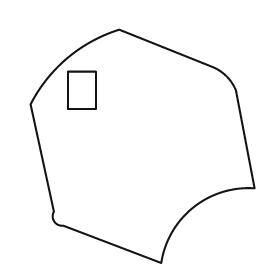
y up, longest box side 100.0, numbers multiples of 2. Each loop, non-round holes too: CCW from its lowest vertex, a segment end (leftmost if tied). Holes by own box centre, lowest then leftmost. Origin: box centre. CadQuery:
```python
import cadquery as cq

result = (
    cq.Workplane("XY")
    .moveTo(8.0, -50.0)
    .threePointArc((22.0, -26.0), (48.0, -18.0))
    .lineTo(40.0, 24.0)
    .threePointArc((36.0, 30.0), (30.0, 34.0))
    .lineTo(-10.0, 50.0)
    .threePointArc((-32.0, 38.0), (-48.0, 18.0))
    .lineTo(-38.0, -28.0)
    .threePointArc((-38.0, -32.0), (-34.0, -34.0))
    .close()
    .moveTo(-32.0, 16.0)
    .lineTo(-20.0, 16.0)
    .lineTo(-20.0, 32.0)
    .lineTo(-32.0, 32.0)
    .close()
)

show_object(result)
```